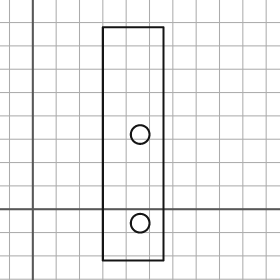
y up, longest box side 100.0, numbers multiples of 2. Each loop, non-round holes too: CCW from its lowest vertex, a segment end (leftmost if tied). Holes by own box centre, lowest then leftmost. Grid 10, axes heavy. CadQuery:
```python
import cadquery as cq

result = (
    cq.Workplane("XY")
    .moveTo(30.0, -22.0)
    .lineTo(56.0, -22.0)
    .lineTo(56.0, 78.0)
    .lineTo(30.0, 78.0)
    .close()
    .moveTo(46.0, -6.0)
    .circle(4.0)
    .moveTo(46.0, 32.0)
    .circle(4.0)
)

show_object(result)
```